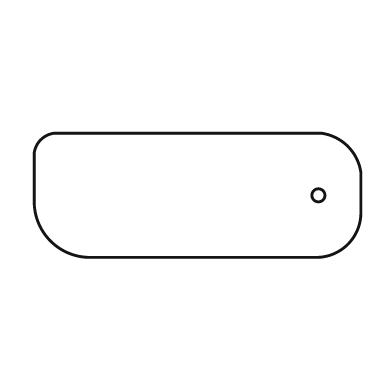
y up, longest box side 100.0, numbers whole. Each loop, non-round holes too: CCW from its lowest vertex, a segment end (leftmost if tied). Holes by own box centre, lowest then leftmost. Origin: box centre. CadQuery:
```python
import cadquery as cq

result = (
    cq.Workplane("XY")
    .moveTo(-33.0, -19.0)
    .lineTo(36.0, -19.0)
    .threePointArc((46.0, -15.0), (50.0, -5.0))
    .lineTo(50.0, 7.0)
    .threePointArc((46.0, 15.0), (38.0, 19.0))
    .lineTo(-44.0, 19.0)
    .threePointArc((-48.0, 17.0), (-50.0, 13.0))
    .lineTo(-50.0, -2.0)
    .threePointArc((-45.0, -14.0), (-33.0, -19.0))
    .close()
    .moveTo(37.0, 0.0)
    .circle(2.0)
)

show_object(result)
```